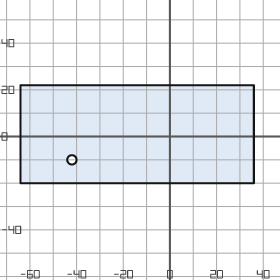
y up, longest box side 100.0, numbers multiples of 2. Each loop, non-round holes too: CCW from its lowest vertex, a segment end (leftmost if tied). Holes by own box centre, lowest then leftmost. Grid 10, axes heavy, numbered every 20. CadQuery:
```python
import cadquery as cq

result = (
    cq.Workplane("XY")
    .moveTo(-64.0, -20.0)
    .lineTo(36.0, -20.0)
    .lineTo(36.0, 22.0)
    .lineTo(-64.0, 22.0)
    .close()
    .moveTo(-42.0, -10.0)
    .circle(2.0)
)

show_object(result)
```